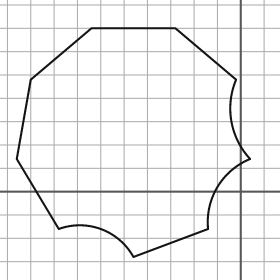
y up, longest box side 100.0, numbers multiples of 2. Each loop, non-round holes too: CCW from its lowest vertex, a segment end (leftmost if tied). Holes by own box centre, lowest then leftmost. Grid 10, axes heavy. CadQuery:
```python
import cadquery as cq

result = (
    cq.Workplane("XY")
    .moveTo(-46.0, -28.0)
    .lineTo(-14.0, -16.0)
    .threePointArc((-10.0, 2.0), (4.0, 14.0))
    .threePointArc((-4.0, 30.0), (-2.0, 48.0))
    .lineTo(-28.0, 70.0)
    .lineTo(-64.0, 70.0)
    .lineTo(-90.0, 48.0)
    .lineTo(-96.0, 14.0)
    .lineTo(-78.0, -16.0)
    .threePointArc((-60.0, -16.0), (-46.0, -28.0))
    .close()
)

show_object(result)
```